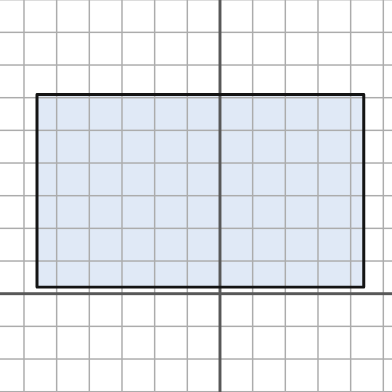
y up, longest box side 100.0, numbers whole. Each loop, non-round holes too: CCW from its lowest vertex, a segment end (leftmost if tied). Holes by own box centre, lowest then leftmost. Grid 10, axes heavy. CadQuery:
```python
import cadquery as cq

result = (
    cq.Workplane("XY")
    .moveTo(-56.0, 2.0)
    .lineTo(44.0, 2.0)
    .lineTo(44.0, 61.0)
    .lineTo(-56.0, 61.0)
    .close()
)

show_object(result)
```